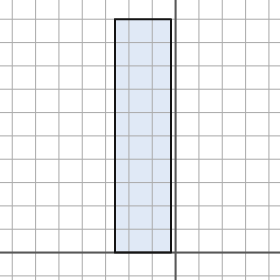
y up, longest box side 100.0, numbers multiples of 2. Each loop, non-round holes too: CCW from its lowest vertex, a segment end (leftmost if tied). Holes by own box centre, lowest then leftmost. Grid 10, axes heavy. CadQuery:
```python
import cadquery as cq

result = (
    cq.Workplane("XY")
    .moveTo(-26.0, 0.0)
    .lineTo(-2.0, 0.0)
    .lineTo(-2.0, 100.0)
    .lineTo(-26.0, 100.0)
    .close()
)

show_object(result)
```